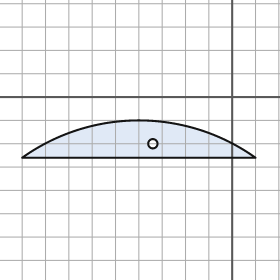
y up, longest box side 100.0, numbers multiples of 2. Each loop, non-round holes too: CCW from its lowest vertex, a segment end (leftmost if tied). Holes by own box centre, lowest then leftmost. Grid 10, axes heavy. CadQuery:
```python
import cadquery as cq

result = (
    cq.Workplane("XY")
    .moveTo(-90.0, -26.0)
    .lineTo(10.0, -26.0)
    .threePointArc((-40.0, -10.0), (-90.0, -26.0))
    .close()
    .moveTo(-34.0, -20.0)
    .circle(2.0)
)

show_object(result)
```